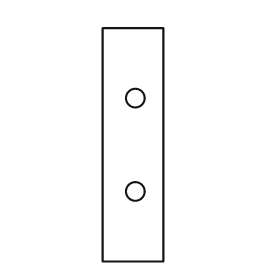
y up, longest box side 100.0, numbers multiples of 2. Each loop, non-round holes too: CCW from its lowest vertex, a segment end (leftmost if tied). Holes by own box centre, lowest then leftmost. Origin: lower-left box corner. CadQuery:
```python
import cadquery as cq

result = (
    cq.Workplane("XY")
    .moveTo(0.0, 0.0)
    .lineTo(26.0, 0.0)
    .lineTo(26.0, 100.0)
    .lineTo(0.0, 100.0)
    .close()
    .moveTo(14.0, 30.0)
    .circle(4.0)
    .moveTo(14.0, 70.0)
    .circle(4.0)
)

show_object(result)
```